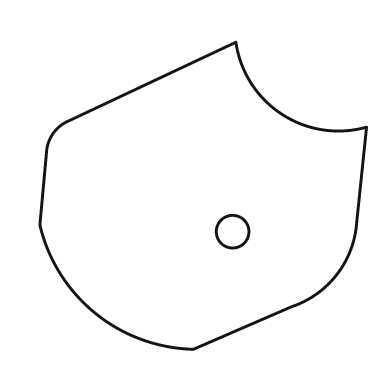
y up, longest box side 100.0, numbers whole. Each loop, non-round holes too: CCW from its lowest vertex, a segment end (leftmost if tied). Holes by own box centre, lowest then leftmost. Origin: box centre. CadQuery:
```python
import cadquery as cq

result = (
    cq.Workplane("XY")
    .moveTo(-3.0, -47.0)
    .lineTo(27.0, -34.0)
    .threePointArc((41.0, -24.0), (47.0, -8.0))
    .lineTo(50.0, 21.0)
    .threePointArc((24.0, 25.0), (10.0, 47.0))
    .lineTo(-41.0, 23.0)
    .threePointArc((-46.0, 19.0), (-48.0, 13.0))
    .lineTo(-50.0, -9.0)
    .threePointArc((-33.0, -36.0), (-3.0, -47.0))
    .close()
    .moveTo(9.0, -11.0)
    .circle(5.0)
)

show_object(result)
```